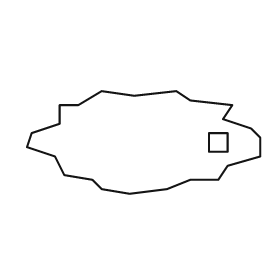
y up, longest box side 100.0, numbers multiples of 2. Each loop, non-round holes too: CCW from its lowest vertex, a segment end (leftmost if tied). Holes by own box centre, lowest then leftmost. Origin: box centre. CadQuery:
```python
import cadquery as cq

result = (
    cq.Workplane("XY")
    .moveTo(-6.0, -22.0)
    .lineTo(10.0, -20.0)
    .lineTo(20.0, -16.0)
    .lineTo(32.0, -16.0)
    .lineTo(36.0, -10.0)
    .lineTo(50.0, -6.0)
    .lineTo(50.0, 2.0)
    .lineTo(46.0, 6.0)
    .lineTo(34.0, 10.0)
    .lineTo(38.0, 16.0)
    .lineTo(20.0, 18.0)
    .lineTo(14.0, 22.0)
    .lineTo(-4.0, 20.0)
    .lineTo(-18.0, 22.0)
    .lineTo(-28.0, 16.0)
    .lineTo(-36.0, 16.0)
    .lineTo(-36.0, 8.0)
    .lineTo(-48.0, 4.0)
    .lineTo(-50.0, -2.0)
    .lineTo(-38.0, -6.0)
    .lineTo(-34.0, -14.0)
    .lineTo(-22.0, -16.0)
    .lineTo(-18.0, -20.0)
    .close()
    .moveTo(28.0, -4.0)
    .lineTo(36.0, -4.0)
    .lineTo(36.0, 4.0)
    .lineTo(28.0, 4.0)
    .close()
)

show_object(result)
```